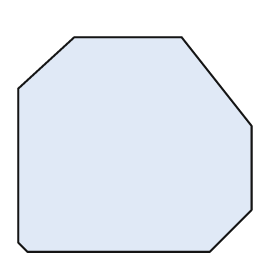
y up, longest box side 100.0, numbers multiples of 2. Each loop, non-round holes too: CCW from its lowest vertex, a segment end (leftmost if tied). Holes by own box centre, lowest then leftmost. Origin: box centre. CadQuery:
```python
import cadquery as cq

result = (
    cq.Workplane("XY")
    .moveTo(-46.0, -46.0)
    .lineTo(32.0, -46.0)
    .lineTo(50.0, -28.0)
    .lineTo(50.0, 8.0)
    .lineTo(20.0, 46.0)
    .lineTo(-26.0, 46.0)
    .lineTo(-50.0, 24.0)
    .lineTo(-50.0, -42.0)
    .close()
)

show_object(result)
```